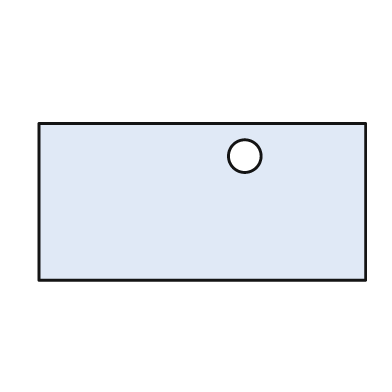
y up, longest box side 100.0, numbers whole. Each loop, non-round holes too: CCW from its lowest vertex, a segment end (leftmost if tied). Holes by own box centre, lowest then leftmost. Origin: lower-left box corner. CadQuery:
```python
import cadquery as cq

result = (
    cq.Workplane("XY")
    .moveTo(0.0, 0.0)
    .lineTo(100.0, 0.0)
    .lineTo(100.0, 48.0)
    .lineTo(0.0, 48.0)
    .close()
    .moveTo(63.0, 38.0)
    .circle(5.0)
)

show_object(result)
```